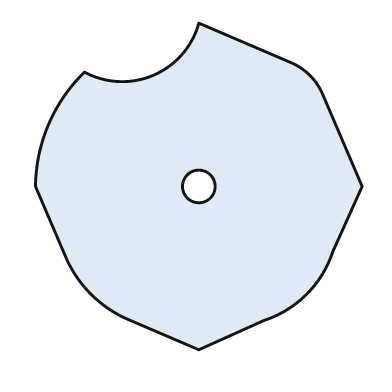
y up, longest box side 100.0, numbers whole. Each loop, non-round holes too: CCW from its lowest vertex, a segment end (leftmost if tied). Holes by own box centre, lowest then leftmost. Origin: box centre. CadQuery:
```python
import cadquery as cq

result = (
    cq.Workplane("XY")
    .moveTo(0.0, -50.0)
    .lineTo(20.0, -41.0)
    .threePointArc((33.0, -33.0), (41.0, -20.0))
    .lineTo(50.0, 0.0)
    .lineTo(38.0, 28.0)
    .threePointArc((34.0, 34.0), (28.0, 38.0))
    .lineTo(0.0, 50.0)
    .threePointArc((-14.0, 34.0), (-35.0, 35.0))
    .threePointArc((-46.0, 19.0), (-50.0, 0.0))
    .lineTo(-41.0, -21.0)
    .threePointArc((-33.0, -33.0), (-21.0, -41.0))
    .close()
    .moveTo(0.0, 0.0)
    .circle(5.0)
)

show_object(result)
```